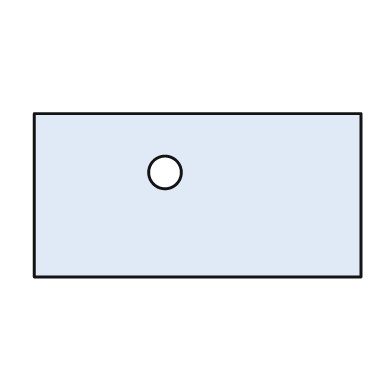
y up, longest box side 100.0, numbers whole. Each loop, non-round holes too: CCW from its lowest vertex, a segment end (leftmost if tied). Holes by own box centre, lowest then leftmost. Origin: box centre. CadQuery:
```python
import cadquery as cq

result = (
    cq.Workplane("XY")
    .moveTo(-50.0, -25.0)
    .lineTo(50.0, -25.0)
    .lineTo(50.0, 25.0)
    .lineTo(-50.0, 25.0)
    .close()
    .moveTo(-10.0, 7.0)
    .circle(5.0)
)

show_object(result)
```